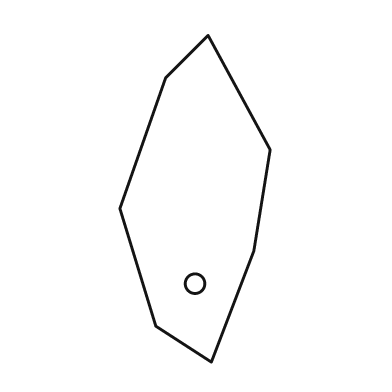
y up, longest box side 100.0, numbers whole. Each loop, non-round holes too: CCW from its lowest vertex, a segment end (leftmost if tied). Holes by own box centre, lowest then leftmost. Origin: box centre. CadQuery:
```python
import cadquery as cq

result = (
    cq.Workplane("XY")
    .moveTo(5.0, -50.0)
    .lineTo(18.0, -16.0)
    .lineTo(23.0, 15.0)
    .lineTo(4.0, 50.0)
    .lineTo(-9.0, 37.0)
    .lineTo(-23.0, -3.0)
    .lineTo(-12.0, -39.0)
    .close()
    .moveTo(0.0, -26.0)
    .circle(3.0)
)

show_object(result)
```